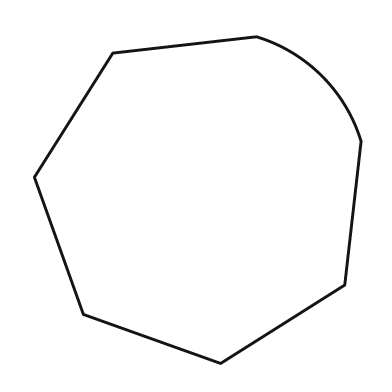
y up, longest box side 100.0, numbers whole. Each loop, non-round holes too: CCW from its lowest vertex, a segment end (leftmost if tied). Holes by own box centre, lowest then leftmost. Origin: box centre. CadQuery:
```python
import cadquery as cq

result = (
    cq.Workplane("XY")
    .moveTo(7.0, -50.0)
    .lineTo(45.0, -26.0)
    .lineTo(50.0, 18.0)
    .threePointArc((38.0, 38.0), (18.0, 50.0))
    .lineTo(-26.0, 45.0)
    .lineTo(-50.0, 7.0)
    .lineTo(-35.0, -35.0)
    .close()
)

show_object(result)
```